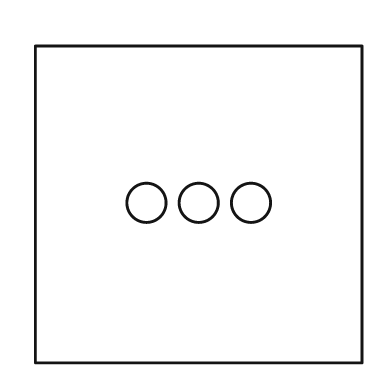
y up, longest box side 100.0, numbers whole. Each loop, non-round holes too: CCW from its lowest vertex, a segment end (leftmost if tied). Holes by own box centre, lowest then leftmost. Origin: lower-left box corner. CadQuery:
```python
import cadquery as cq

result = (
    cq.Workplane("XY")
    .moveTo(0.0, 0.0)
    .lineTo(100.0, 0.0)
    .lineTo(100.0, 97.0)
    .lineTo(0.0, 97.0)
    .close()
    .moveTo(34.0, 49.0)
    .circle(6.0)
    .moveTo(50.0, 49.0)
    .circle(6.0)
    .moveTo(66.0, 49.0)
    .circle(6.0)
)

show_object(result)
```